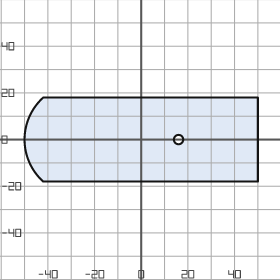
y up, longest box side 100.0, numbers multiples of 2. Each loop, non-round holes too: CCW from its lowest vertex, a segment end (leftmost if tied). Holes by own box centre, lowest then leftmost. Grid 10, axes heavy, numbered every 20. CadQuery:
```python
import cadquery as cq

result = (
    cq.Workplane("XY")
    .moveTo(-42.0, -18.0)
    .lineTo(50.0, -18.0)
    .lineTo(50.0, 18.0)
    .lineTo(-42.0, 18.0)
    .threePointArc((-50.0, 0.0), (-42.0, -18.0))
    .close()
    .moveTo(16.0, 0.0)
    .circle(2.0)
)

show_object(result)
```